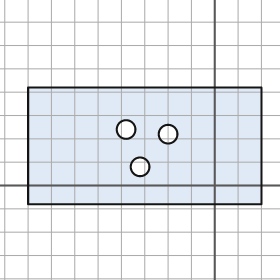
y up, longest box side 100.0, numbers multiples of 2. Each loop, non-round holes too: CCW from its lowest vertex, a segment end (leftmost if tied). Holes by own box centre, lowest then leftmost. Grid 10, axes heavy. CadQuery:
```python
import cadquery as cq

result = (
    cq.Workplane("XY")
    .moveTo(-80.0, -8.0)
    .lineTo(20.0, -8.0)
    .lineTo(20.0, 42.0)
    .lineTo(-80.0, 42.0)
    .close()
    .moveTo(-32.0, 8.0)
    .circle(4.0)
    .moveTo(-20.0, 22.0)
    .circle(4.0)
    .moveTo(-38.0, 24.0)
    .circle(4.0)
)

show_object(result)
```